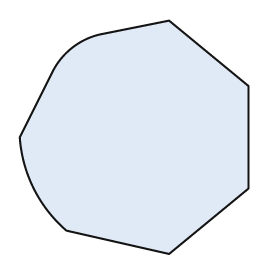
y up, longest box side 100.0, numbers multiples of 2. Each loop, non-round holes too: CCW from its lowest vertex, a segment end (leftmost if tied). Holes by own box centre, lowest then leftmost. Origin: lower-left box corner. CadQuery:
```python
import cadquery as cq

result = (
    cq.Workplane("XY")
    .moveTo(64.0, 0.0)
    .lineTo(98.0, 28.0)
    .lineTo(98.0, 72.0)
    .lineTo(64.0, 100.0)
    .lineTo(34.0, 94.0)
    .threePointArc((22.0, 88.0), (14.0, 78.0))
    .lineTo(0.0, 50.0)
    .threePointArc((6.0, 28.0), (20.0, 10.0))
    .close()
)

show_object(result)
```